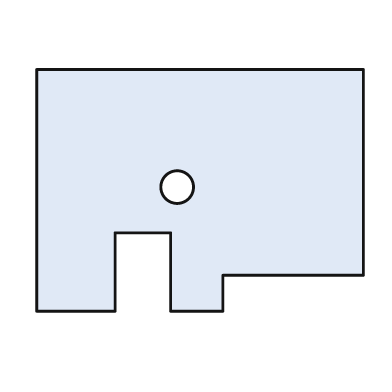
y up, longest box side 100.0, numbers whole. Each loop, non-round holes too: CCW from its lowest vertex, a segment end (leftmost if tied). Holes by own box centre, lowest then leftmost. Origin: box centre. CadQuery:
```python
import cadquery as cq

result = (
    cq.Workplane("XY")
    .moveTo(-50.0, -37.0)
    .lineTo(-26.0, -37.0)
    .lineTo(-26.0, -13.0)
    .lineTo(-9.0, -13.0)
    .lineTo(-9.0, -37.0)
    .lineTo(7.0, -37.0)
    .lineTo(7.0, -26.0)
    .lineTo(50.0, -26.0)
    .lineTo(50.0, 37.0)
    .lineTo(-50.0, 37.0)
    .close()
    .moveTo(-7.0, 1.0)
    .circle(5.0)
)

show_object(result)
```